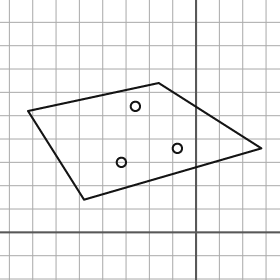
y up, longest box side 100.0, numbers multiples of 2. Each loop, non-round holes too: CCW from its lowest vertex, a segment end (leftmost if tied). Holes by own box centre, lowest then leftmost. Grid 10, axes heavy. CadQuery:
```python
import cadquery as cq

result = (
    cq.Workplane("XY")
    .moveTo(-48.0, 14.0)
    .lineTo(28.0, 36.0)
    .lineTo(-16.0, 64.0)
    .lineTo(-72.0, 52.0)
    .close()
    .moveTo(-32.0, 30.0)
    .circle(2.0)
    .moveTo(-8.0, 36.0)
    .circle(2.0)
    .moveTo(-26.0, 54.0)
    .circle(2.0)
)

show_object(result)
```